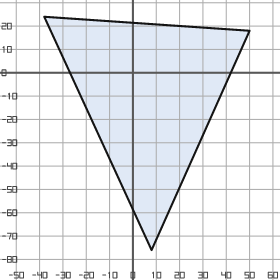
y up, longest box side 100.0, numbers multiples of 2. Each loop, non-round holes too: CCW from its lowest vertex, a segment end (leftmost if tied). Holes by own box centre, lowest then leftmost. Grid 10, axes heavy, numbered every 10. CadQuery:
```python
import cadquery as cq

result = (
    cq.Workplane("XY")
    .moveTo(8.0, -76.0)
    .lineTo(50.0, 18.0)
    .lineTo(-38.0, 24.0)
    .close()
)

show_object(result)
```